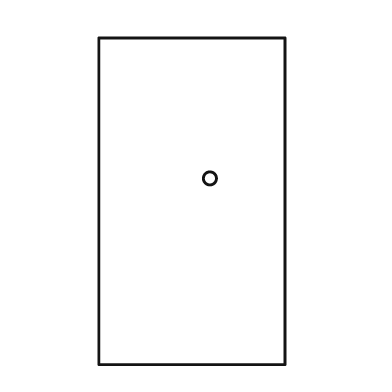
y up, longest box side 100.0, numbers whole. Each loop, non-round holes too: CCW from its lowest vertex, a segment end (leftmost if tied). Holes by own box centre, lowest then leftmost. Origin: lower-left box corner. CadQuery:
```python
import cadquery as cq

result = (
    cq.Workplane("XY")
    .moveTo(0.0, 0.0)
    .lineTo(57.0, 0.0)
    .lineTo(57.0, 100.0)
    .lineTo(0.0, 100.0)
    .close()
    .moveTo(34.0, 57.0)
    .circle(2.0)
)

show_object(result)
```